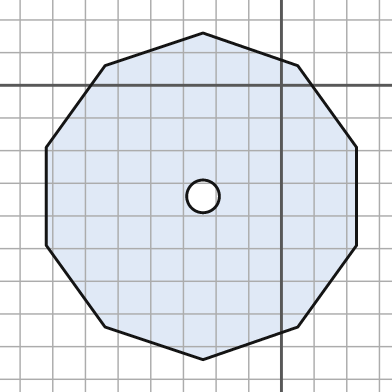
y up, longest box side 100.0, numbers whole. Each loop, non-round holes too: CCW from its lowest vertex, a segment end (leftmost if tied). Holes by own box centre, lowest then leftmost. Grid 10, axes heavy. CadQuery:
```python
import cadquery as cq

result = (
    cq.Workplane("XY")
    .moveTo(-24.0, -84.0)
    .lineTo(5.0, -74.0)
    .lineTo(23.0, -49.0)
    .lineTo(23.0, -19.0)
    .lineTo(5.0, 6.0)
    .lineTo(-24.0, 16.0)
    .lineTo(-54.0, 6.0)
    .lineTo(-72.0, -19.0)
    .lineTo(-72.0, -49.0)
    .lineTo(-54.0, -74.0)
    .close()
    .moveTo(-24.0, -34.0)
    .circle(5.0)
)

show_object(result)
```